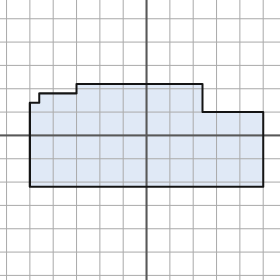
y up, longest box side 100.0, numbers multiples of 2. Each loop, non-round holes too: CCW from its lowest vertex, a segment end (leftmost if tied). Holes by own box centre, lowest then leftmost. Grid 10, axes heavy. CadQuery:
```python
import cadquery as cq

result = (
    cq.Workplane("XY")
    .moveTo(-50.0, -22.0)
    .lineTo(50.0, -22.0)
    .lineTo(50.0, 10.0)
    .lineTo(24.0, 10.0)
    .lineTo(24.0, 22.0)
    .lineTo(-30.0, 22.0)
    .lineTo(-30.0, 18.0)
    .lineTo(-46.0, 18.0)
    .lineTo(-46.0, 14.0)
    .lineTo(-50.0, 14.0)
    .close()
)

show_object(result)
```